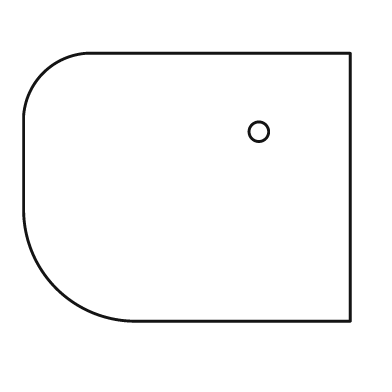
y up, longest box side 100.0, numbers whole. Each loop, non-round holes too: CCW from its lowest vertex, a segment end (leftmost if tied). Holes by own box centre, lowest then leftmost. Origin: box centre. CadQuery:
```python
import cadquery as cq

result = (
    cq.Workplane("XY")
    .moveTo(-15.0, -41.0)
    .lineTo(50.0, -41.0)
    .lineTo(50.0, 41.0)
    .lineTo(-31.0, 41.0)
    .threePointArc((-44.0, 35.0), (-50.0, 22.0))
    .lineTo(-50.0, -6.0)
    .threePointArc((-40.0, -31.0), (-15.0, -41.0))
    .close()
    .moveTo(22.0, 17.0)
    .circle(3.0)
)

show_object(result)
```